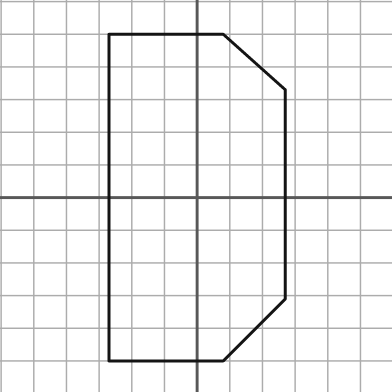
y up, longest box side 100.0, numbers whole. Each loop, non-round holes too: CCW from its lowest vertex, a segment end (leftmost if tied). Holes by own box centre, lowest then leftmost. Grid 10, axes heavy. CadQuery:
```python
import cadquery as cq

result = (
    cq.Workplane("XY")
    .moveTo(-27.0, -50.0)
    .lineTo(8.0, -50.0)
    .lineTo(27.0, -31.0)
    .lineTo(27.0, 33.0)
    .lineTo(8.0, 50.0)
    .lineTo(-27.0, 50.0)
    .close()
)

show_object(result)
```